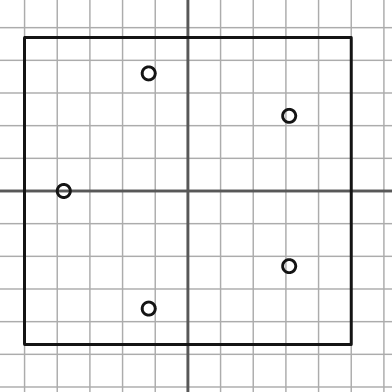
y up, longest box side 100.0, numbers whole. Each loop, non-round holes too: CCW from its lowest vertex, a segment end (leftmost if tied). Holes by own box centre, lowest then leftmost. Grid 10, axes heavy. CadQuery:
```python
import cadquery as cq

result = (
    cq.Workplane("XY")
    .moveTo(-50.0, -47.0)
    .lineTo(50.0, -47.0)
    .lineTo(50.0, 47.0)
    .lineTo(-50.0, 47.0)
    .close()
    .moveTo(-12.0, -36.0)
    .circle(2.0)
    .moveTo(31.0, -23.0)
    .circle(2.0)
    .moveTo(-38.0, 0.0)
    .circle(2.0)
    .moveTo(31.0, 23.0)
    .circle(2.0)
    .moveTo(-12.0, 36.0)
    .circle(2.0)
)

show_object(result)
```